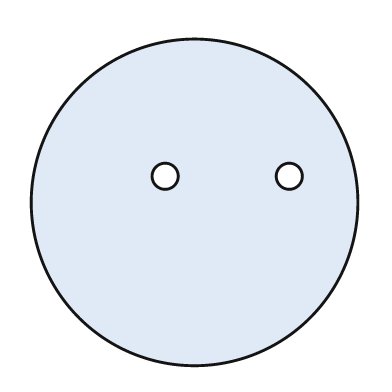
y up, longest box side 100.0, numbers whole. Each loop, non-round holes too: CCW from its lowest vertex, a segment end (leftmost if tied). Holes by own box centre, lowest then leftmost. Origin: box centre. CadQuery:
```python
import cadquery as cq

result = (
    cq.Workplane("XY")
    .moveTo(0.0, 0.0)
    .circle(50.0)
    .moveTo(-9.0, 8.0)
    .circle(4.0)
    .moveTo(29.0, 8.0)
    .circle(4.0)
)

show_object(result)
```